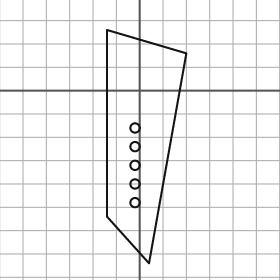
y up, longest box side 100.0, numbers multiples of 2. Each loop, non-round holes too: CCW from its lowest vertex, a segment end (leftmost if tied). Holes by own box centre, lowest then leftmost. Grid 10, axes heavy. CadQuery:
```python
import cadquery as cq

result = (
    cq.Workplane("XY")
    .moveTo(4.0, -74.0)
    .lineTo(20.0, 16.0)
    .lineTo(-14.0, 26.0)
    .lineTo(-14.0, -54.0)
    .close()
    .moveTo(-2.0, -48.0)
    .circle(2.0)
    .moveTo(-2.0, -40.0)
    .circle(2.0)
    .moveTo(-2.0, -32.0)
    .circle(2.0)
    .moveTo(-2.0, -24.0)
    .circle(2.0)
    .moveTo(-2.0, -16.0)
    .circle(2.0)
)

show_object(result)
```